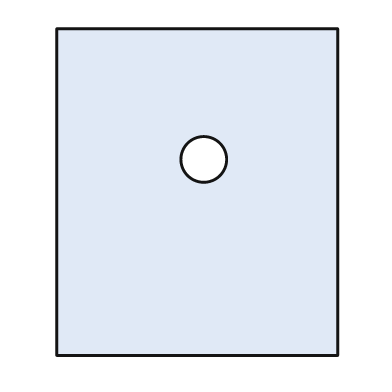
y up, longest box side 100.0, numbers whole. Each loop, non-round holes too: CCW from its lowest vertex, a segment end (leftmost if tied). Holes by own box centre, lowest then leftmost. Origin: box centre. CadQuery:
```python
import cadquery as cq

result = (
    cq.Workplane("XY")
    .moveTo(-43.0, -50.0)
    .lineTo(43.0, -50.0)
    .lineTo(43.0, 50.0)
    .lineTo(-43.0, 50.0)
    .close()
    .moveTo(2.0, 10.0)
    .circle(7.0)
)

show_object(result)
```